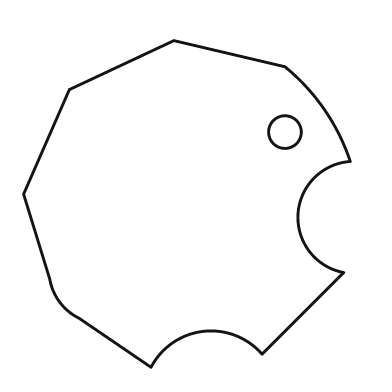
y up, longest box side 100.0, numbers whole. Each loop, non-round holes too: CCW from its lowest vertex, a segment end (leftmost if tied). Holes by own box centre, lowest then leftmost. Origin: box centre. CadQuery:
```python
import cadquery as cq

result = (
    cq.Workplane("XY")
    .moveTo(-11.0, -50.0)
    .threePointArc((5.0, -39.0), (23.0, -46.0))
    .lineTo(48.0, -21.0)
    .threePointArc((34.0, -3.0), (50.0, 13.0))
    .threePointArc((42.0, 29.0), (30.0, 42.0))
    .lineTo(-4.0, 50.0)
    .lineTo(-36.0, 35.0)
    .lineTo(-50.0, 3.0)
    .lineTo(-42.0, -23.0)
    .threePointArc((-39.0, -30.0), (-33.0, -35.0))
    .close()
    .moveTo(30.0, 22.0)
    .circle(5.0)
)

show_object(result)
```